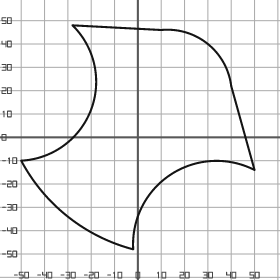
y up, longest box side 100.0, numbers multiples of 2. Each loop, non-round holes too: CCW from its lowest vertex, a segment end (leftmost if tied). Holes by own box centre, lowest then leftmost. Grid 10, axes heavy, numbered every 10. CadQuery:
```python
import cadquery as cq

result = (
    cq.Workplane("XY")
    .moveTo(-2.0, -48.0)
    .threePointArc((14.0, -16.0), (50.0, -14.0))
    .lineTo(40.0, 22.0)
    .threePointArc((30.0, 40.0), (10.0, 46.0))
    .lineTo(-28.0, 48.0)
    .threePointArc((-20.0, 12.0), (-50.0, -10.0))
    .threePointArc((-30.0, -34.0), (-2.0, -48.0))
    .close()
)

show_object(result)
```